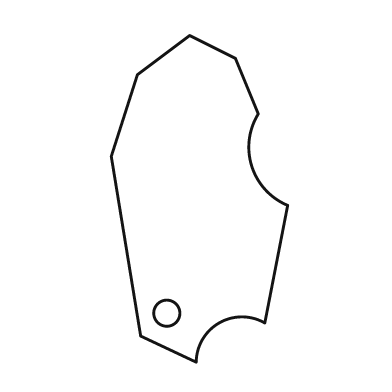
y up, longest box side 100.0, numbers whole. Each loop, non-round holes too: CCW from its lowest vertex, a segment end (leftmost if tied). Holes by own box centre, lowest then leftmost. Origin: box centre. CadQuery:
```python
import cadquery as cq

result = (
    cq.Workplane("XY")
    .moveTo(-1.0, -50.0)
    .threePointArc((6.0, -38.0), (20.0, -38.0))
    .lineTo(27.0, -2.0)
    .threePointArc((16.0, 10.0), (18.0, 26.0))
    .lineTo(11.0, 43.0)
    .lineTo(-3.0, 50.0)
    .lineTo(-19.0, 38.0)
    .lineTo(-27.0, 13.0)
    .lineTo(-18.0, -42.0)
    .close()
    .moveTo(-10.0, -35.0)
    .circle(4.0)
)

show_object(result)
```